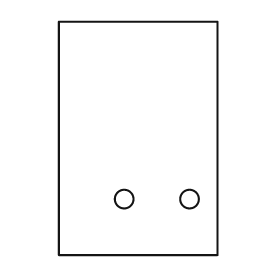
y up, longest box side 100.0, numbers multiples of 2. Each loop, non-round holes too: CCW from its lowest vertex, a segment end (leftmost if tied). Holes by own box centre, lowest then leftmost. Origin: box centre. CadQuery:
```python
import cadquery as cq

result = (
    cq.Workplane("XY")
    .moveTo(-34.0, -50.0)
    .lineTo(34.0, -50.0)
    .lineTo(34.0, 50.0)
    .lineTo(-34.0, 50.0)
    .close()
    .moveTo(-6.0, -26.0)
    .circle(4.0)
    .moveTo(22.0, -26.0)
    .circle(4.0)
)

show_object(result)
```